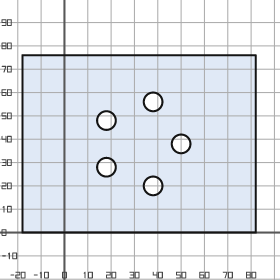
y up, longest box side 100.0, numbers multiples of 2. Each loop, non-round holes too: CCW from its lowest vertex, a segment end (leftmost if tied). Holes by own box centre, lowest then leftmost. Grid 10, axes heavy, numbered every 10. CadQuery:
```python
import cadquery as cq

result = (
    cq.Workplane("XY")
    .moveTo(-18.0, 0.0)
    .lineTo(82.0, 0.0)
    .lineTo(82.0, 76.0)
    .lineTo(-18.0, 76.0)
    .close()
    .moveTo(38.0, 20.0)
    .circle(4.0)
    .moveTo(18.0, 28.0)
    .circle(4.0)
    .moveTo(50.0, 38.0)
    .circle(4.0)
    .moveTo(18.0, 48.0)
    .circle(4.0)
    .moveTo(38.0, 56.0)
    .circle(4.0)
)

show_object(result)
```